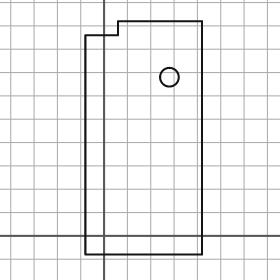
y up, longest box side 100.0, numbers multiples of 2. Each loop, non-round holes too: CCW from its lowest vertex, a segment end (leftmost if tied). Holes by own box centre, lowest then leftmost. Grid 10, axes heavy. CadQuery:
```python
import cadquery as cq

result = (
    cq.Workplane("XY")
    .moveTo(-8.0, -8.0)
    .lineTo(42.0, -8.0)
    .lineTo(42.0, 92.0)
    .lineTo(6.0, 92.0)
    .lineTo(6.0, 86.0)
    .lineTo(-8.0, 86.0)
    .close()
    .moveTo(28.0, 68.0)
    .circle(4.0)
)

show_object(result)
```